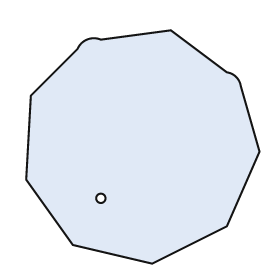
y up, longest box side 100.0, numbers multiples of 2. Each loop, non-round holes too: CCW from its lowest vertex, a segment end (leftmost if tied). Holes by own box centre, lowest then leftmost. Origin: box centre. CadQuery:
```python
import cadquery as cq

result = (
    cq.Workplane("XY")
    .moveTo(4.0, -50.0)
    .lineTo(36.0, -34.0)
    .lineTo(50.0, -2.0)
    .lineTo(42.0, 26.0)
    .threePointArc((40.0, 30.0), (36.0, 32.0))
    .lineTo(12.0, 50.0)
    .lineTo(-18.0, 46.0)
    .threePointArc((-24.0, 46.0), (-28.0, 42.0))
    .lineTo(-48.0, 22.0)
    .lineTo(-50.0, -14.0)
    .lineTo(-30.0, -42.0)
    .close()
    .moveTo(-18.0, -22.0)
    .circle(2.0)
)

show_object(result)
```